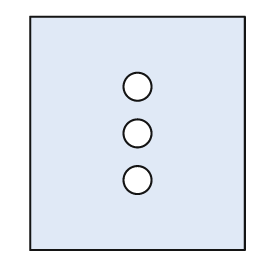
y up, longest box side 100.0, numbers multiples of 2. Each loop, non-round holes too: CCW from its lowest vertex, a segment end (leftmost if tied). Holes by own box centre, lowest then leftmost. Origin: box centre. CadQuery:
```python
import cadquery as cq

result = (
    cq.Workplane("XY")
    .moveTo(-46.0, -50.0)
    .lineTo(46.0, -50.0)
    .lineTo(46.0, 50.0)
    .lineTo(-46.0, 50.0)
    .close()
    .moveTo(0.0, -20.0)
    .circle(6.0)
    .moveTo(0.0, 0.0)
    .circle(6.0)
    .moveTo(0.0, 20.0)
    .circle(6.0)
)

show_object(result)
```